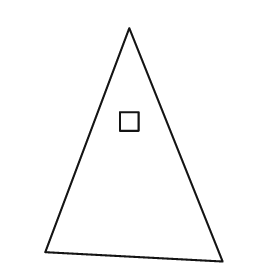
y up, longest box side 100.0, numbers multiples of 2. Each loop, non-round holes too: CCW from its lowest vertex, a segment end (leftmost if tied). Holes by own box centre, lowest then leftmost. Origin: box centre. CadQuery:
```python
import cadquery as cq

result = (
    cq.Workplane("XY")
    .moveTo(38.0, -50.0)
    .lineTo(-2.0, 50.0)
    .lineTo(-38.0, -46.0)
    .close()
    .moveTo(-6.0, 6.0)
    .lineTo(2.0, 6.0)
    .lineTo(2.0, 14.0)
    .lineTo(-6.0, 14.0)
    .close()
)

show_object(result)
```